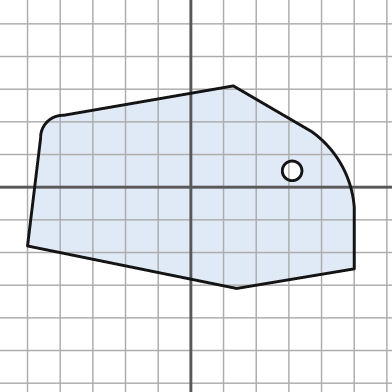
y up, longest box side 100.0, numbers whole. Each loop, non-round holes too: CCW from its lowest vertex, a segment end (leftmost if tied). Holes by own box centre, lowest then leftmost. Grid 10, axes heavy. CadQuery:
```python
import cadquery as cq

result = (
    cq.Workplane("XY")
    .moveTo(14.0, -31.0)
    .lineTo(50.0, -25.0)
    .lineTo(50.0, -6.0)
    .threePointArc((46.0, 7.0), (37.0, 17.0))
    .lineTo(13.0, 31.0)
    .lineTo(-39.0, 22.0)
    .threePointArc((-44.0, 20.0), (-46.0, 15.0))
    .lineTo(-50.0, -18.0)
    .close()
    .moveTo(31.0, 5.0)
    .circle(3.0)
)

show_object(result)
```